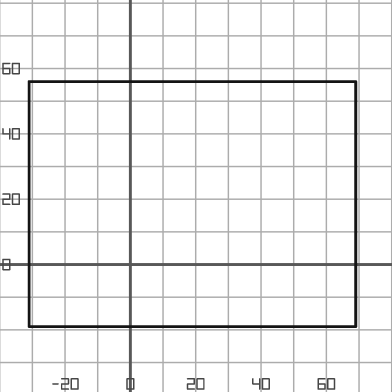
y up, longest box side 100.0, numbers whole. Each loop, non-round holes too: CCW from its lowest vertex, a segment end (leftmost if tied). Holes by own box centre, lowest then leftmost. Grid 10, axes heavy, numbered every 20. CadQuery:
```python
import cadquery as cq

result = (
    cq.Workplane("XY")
    .moveTo(-31.0, -19.0)
    .lineTo(69.0, -19.0)
    .lineTo(69.0, 56.0)
    .lineTo(-31.0, 56.0)
    .close()
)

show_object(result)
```